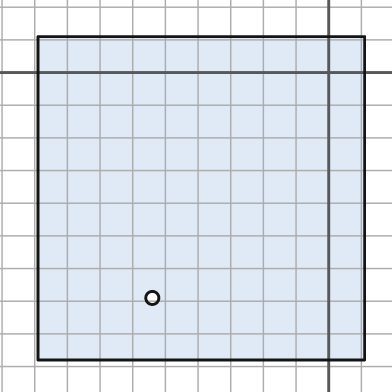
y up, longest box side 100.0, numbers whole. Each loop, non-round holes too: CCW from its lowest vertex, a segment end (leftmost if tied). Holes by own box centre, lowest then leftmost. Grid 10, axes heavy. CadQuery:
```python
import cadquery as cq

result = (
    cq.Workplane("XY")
    .moveTo(-89.0, -88.0)
    .lineTo(11.0, -88.0)
    .lineTo(11.0, 11.0)
    .lineTo(-89.0, 11.0)
    .close()
    .moveTo(-54.0, -69.0)
    .circle(2.0)
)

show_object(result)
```